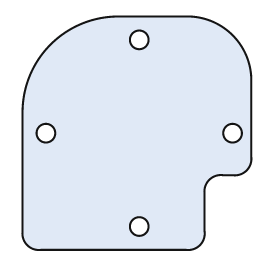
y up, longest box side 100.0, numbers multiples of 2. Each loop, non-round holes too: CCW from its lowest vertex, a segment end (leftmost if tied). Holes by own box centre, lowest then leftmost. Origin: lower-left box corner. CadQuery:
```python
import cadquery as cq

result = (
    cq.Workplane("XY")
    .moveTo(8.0, 0.0)
    .lineTo(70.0, 0.0)
    .threePointArc((76.0, 2.0), (78.0, 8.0))
    .lineTo(78.0, 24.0)
    .threePointArc((80.0, 30.0), (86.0, 32.0))
    .lineTo(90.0, 32.0)
    .threePointArc((96.0, 34.0), (98.0, 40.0))
    .lineTo(98.0, 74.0)
    .threePointArc((90.0, 92.0), (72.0, 100.0))
    .lineTo(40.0, 100.0)
    .threePointArc((12.0, 88.0), (0.0, 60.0))
    .lineTo(0.0, 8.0)
    .threePointArc((2.0, 2.0), (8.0, 0.0))
    .close()
    .moveTo(50.0, 10.0)
    .circle(4.0)
    .moveTo(10.0, 50.0)
    .circle(4.0)
    .moveTo(90.0, 50.0)
    .circle(4.0)
    .moveTo(50.0, 90.0)
    .circle(4.0)
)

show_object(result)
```